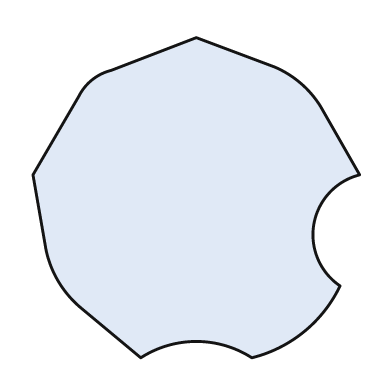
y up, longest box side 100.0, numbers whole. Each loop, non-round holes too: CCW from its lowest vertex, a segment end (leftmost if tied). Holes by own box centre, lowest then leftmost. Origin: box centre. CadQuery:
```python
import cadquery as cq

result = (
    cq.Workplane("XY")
    .moveTo(-17.0, -49.0)
    .threePointArc((0.0, -44.0), (17.0, -49.0))
    .threePointArc((33.0, -41.0), (44.0, -27.0))
    .threePointArc((36.0, -8.0), (50.0, 7.0))
    .lineTo(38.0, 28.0)
    .threePointArc((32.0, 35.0), (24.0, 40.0))
    .lineTo(0.0, 49.0)
    .lineTo(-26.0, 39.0)
    .threePointArc((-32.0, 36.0), (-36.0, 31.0))
    .lineTo(-50.0, 7.0)
    .lineTo(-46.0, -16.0)
    .threePointArc((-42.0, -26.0), (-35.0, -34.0))
    .close()
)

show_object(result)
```